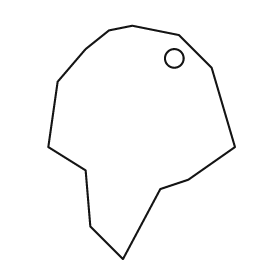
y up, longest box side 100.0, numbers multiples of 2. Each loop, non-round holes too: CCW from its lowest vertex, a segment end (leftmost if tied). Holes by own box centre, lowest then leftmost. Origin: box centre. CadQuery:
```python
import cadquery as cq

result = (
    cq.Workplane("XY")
    .moveTo(-8.0, -50.0)
    .lineTo(8.0, -20.0)
    .lineTo(20.0, -16.0)
    .lineTo(40.0, -2.0)
    .lineTo(30.0, 32.0)
    .lineTo(16.0, 46.0)
    .lineTo(-4.0, 50.0)
    .lineTo(-14.0, 48.0)
    .lineTo(-24.0, 40.0)
    .lineTo(-36.0, 26.0)
    .lineTo(-40.0, -2.0)
    .lineTo(-24.0, -12.0)
    .lineTo(-22.0, -36.0)
    .close()
    .moveTo(14.0, 36.0)
    .circle(4.0)
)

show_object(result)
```